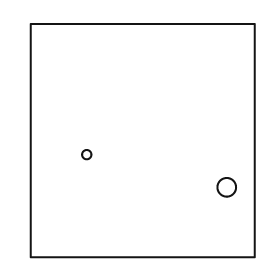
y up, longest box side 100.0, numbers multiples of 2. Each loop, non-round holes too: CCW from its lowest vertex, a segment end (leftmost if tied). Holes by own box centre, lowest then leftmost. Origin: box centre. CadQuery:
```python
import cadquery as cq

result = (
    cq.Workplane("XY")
    .moveTo(-48.0, -50.0)
    .lineTo(48.0, -50.0)
    .lineTo(48.0, 50.0)
    .lineTo(-48.0, 50.0)
    .close()
    .moveTo(36.0, -20.0)
    .circle(4.0)
    .moveTo(-24.0, -6.0)
    .circle(2.0)
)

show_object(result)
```